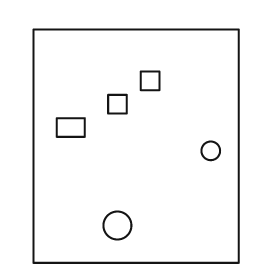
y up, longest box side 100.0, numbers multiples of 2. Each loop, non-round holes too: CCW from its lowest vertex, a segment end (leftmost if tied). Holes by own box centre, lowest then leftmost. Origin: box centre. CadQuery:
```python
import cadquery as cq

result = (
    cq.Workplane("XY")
    .moveTo(-44.0, -50.0)
    .lineTo(44.0, -50.0)
    .lineTo(44.0, 50.0)
    .lineTo(-44.0, 50.0)
    .close()
    .moveTo(-8.0, -34.0)
    .circle(6.0)
    .moveTo(32.0, -2.0)
    .circle(4.0)
    .moveTo(-34.0, 4.0)
    .lineTo(-22.0, 4.0)
    .lineTo(-22.0, 12.0)
    .lineTo(-34.0, 12.0)
    .close()
    .moveTo(-12.0, 14.0)
    .lineTo(-4.0, 14.0)
    .lineTo(-4.0, 22.0)
    .lineTo(-12.0, 22.0)
    .close()
    .moveTo(2.0, 24.0)
    .lineTo(10.0, 24.0)
    .lineTo(10.0, 32.0)
    .lineTo(2.0, 32.0)
    .close()
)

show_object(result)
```